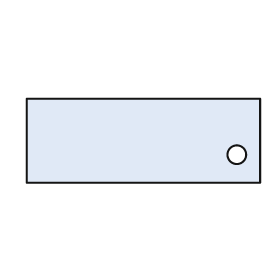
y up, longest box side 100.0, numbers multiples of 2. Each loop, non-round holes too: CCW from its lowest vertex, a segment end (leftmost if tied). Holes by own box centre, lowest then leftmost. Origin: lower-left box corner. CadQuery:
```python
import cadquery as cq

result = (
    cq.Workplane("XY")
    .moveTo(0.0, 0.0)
    .lineTo(100.0, 0.0)
    .lineTo(100.0, 36.0)
    .lineTo(0.0, 36.0)
    .close()
    .moveTo(90.0, 12.0)
    .circle(4.0)
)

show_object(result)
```